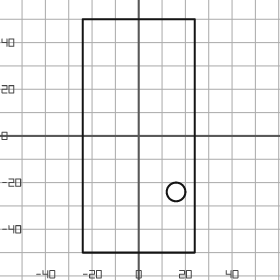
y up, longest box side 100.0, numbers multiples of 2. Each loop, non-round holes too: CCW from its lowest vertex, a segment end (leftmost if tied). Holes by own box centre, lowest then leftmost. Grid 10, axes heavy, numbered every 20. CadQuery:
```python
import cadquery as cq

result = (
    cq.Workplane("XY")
    .moveTo(-24.0, -50.0)
    .lineTo(24.0, -50.0)
    .lineTo(24.0, 50.0)
    .lineTo(-24.0, 50.0)
    .close()
    .moveTo(16.0, -24.0)
    .circle(4.0)
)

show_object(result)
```